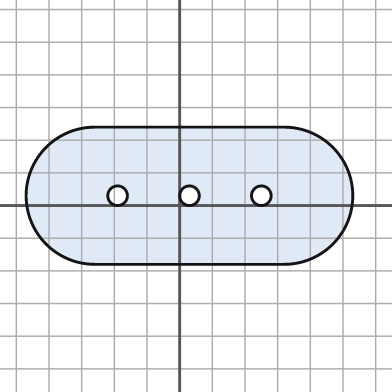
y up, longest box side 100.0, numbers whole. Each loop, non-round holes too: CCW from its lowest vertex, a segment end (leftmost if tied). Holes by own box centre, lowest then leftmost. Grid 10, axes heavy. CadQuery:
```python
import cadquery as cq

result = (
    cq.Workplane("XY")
    .moveTo(-26.0, -18.0)
    .lineTo(32.0, -18.0)
    .threePointArc((53.0, 3.0), (32.0, 24.0))
    .lineTo(-26.0, 24.0)
    .threePointArc((-47.0, 3.0), (-26.0, -18.0))
    .close()
    .moveTo(-19.0, 3.0)
    .circle(3.0)
    .moveTo(3.0, 3.0)
    .circle(3.0)
    .moveTo(25.0, 3.0)
    .circle(3.0)
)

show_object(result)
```